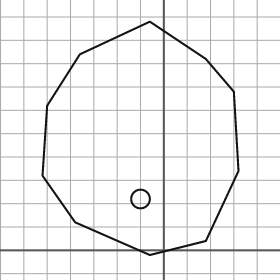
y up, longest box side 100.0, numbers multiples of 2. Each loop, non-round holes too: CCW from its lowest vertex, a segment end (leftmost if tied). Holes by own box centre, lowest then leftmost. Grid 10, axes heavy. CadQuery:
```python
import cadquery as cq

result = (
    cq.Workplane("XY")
    .moveTo(-6.0, -2.0)
    .lineTo(18.0, 4.0)
    .lineTo(32.0, 34.0)
    .lineTo(30.0, 68.0)
    .lineTo(18.0, 82.0)
    .lineTo(-6.0, 98.0)
    .lineTo(-36.0, 84.0)
    .lineTo(-50.0, 62.0)
    .lineTo(-52.0, 32.0)
    .lineTo(-38.0, 12.0)
    .close()
    .moveTo(-10.0, 22.0)
    .circle(4.0)
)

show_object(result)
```